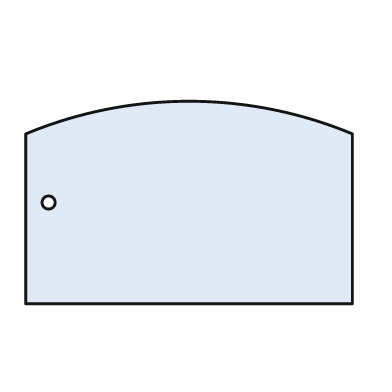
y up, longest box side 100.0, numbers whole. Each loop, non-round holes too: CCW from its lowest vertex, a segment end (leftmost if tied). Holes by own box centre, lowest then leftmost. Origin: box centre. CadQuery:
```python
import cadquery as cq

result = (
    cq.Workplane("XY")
    .moveTo(-50.0, -31.0)
    .lineTo(50.0, -31.0)
    .lineTo(50.0, 21.0)
    .threePointArc((0.0, 31.0), (-50.0, 21.0))
    .close()
    .moveTo(-43.0, 0.0)
    .circle(2.0)
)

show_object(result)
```